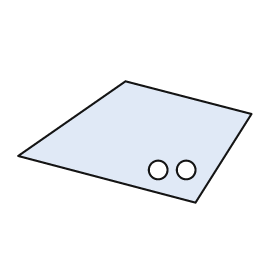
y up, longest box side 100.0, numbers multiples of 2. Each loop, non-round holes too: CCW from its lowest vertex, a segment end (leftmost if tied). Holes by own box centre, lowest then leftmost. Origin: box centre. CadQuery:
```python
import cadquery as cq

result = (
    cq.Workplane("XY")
    .moveTo(26.0, -26.0)
    .lineTo(50.0, 12.0)
    .lineTo(-4.0, 26.0)
    .lineTo(-50.0, -6.0)
    .close()
    .moveTo(10.0, -12.0)
    .circle(4.0)
    .moveTo(22.0, -12.0)
    .circle(4.0)
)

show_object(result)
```